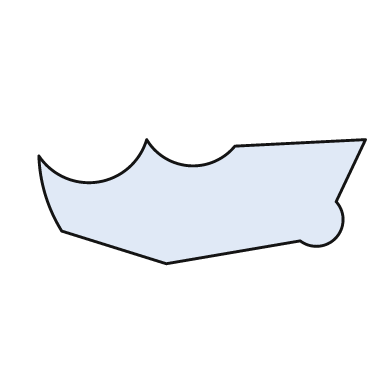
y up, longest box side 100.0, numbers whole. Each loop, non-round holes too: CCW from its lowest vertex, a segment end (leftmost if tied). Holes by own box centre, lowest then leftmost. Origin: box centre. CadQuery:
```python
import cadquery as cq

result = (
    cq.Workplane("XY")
    .moveTo(-11.0, -19.0)
    .lineTo(30.0, -12.0)
    .threePointArc((41.0, -11.0), (41.0, 0.0))
    .lineTo(50.0, 19.0)
    .lineTo(10.0, 17.0)
    .threePointArc((-4.0, 11.0), (-17.0, 19.0))
    .threePointArc((-32.0, 6.0), (-50.0, 14.0))
    .threePointArc((-48.0, 2.0), (-43.0, -9.0))
    .close()
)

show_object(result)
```